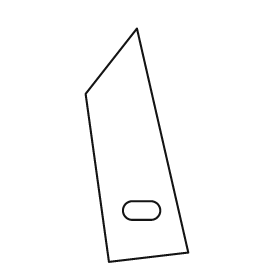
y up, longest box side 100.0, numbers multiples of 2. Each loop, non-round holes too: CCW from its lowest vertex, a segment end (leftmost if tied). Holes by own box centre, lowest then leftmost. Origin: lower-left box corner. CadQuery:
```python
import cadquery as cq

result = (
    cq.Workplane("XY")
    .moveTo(10.0, 0.0)
    .lineTo(44.0, 4.0)
    .lineTo(22.0, 100.0)
    .lineTo(0.0, 72.0)
    .close()
    .moveTo(20.0, 18.0)
    .lineTo(28.0, 18.0)
    .threePointArc((32.0, 22.0), (28.0, 26.0))
    .lineTo(20.0, 26.0)
    .threePointArc((16.0, 22.0), (20.0, 18.0))
    .close()
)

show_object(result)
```